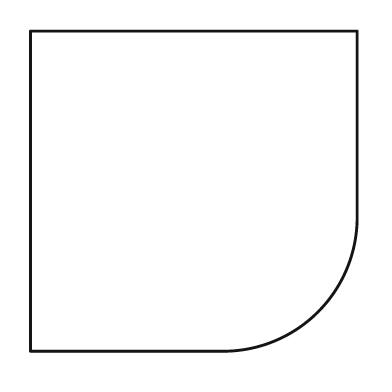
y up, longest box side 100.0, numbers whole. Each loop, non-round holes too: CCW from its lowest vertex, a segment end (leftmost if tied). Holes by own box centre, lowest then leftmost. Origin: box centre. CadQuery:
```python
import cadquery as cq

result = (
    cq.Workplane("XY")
    .moveTo(-50.0, -49.0)
    .lineTo(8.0, -49.0)
    .threePointArc((38.0, -37.0), (50.0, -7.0))
    .lineTo(50.0, 49.0)
    .lineTo(-50.0, 49.0)
    .close()
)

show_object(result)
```